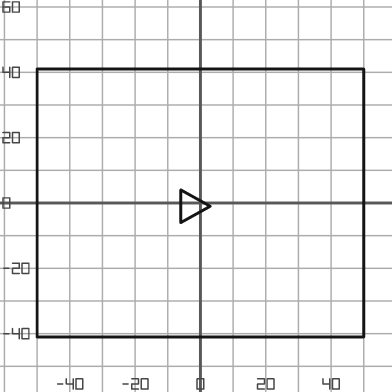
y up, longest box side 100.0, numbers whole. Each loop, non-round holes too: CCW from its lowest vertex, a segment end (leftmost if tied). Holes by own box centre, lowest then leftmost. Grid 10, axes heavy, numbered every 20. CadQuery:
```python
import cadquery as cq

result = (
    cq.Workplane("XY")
    .moveTo(-50.0, -41.0)
    .lineTo(50.0, -41.0)
    .lineTo(50.0, 41.0)
    .lineTo(-50.0, 41.0)
    .close()
    .moveTo(-6.0, -6.0)
    .lineTo(3.0, -1.0)
    .lineTo(-6.0, 4.0)
    .close()
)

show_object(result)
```